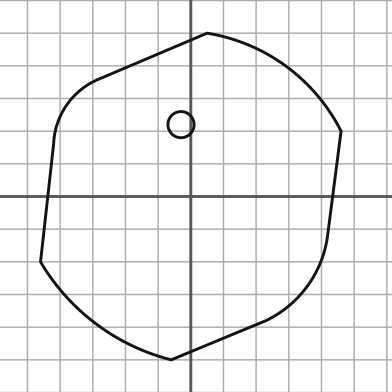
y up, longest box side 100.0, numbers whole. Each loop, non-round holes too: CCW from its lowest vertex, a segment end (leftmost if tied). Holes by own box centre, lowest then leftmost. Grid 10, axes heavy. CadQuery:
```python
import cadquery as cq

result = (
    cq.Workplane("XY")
    .moveTo(-6.0, -50.0)
    .lineTo(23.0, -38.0)
    .threePointArc((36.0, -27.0), (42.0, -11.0))
    .lineTo(46.0, 20.0)
    .threePointArc((29.0, 40.0), (5.0, 50.0))
    .lineTo(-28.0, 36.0)
    .threePointArc((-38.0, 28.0), (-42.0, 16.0))
    .lineTo(-46.0, -20.0)
    .threePointArc((-29.0, -39.0), (-6.0, -50.0))
    .close()
    .moveTo(-3.0, 22.0)
    .circle(4.0)
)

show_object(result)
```